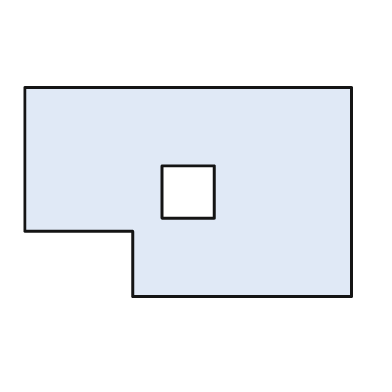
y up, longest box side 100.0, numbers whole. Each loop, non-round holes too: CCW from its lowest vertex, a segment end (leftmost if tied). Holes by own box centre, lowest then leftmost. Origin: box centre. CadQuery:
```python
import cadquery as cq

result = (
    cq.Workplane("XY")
    .moveTo(-17.0, -32.0)
    .lineTo(50.0, -32.0)
    .lineTo(50.0, 32.0)
    .lineTo(-50.0, 32.0)
    .lineTo(-50.0, -12.0)
    .lineTo(-17.0, -12.0)
    .close()
    .moveTo(-8.0, -8.0)
    .lineTo(8.0, -8.0)
    .lineTo(8.0, 8.0)
    .lineTo(-8.0, 8.0)
    .close()
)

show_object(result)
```